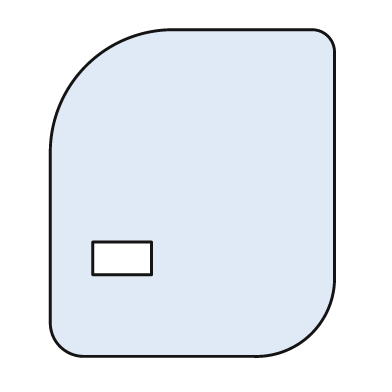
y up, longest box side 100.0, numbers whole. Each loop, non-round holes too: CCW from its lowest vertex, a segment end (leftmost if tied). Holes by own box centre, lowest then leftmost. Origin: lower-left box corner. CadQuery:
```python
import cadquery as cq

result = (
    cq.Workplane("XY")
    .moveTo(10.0, 0.0)
    .lineTo(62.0, 0.0)
    .threePointArc((80.0, 7.0), (87.0, 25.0))
    .lineTo(87.0, 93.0)
    .threePointArc((85.0, 98.0), (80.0, 100.0))
    .lineTo(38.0, 100.0)
    .threePointArc((11.0, 89.0), (0.0, 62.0))
    .lineTo(0.0, 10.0)
    .threePointArc((3.0, 3.0), (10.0, 0.0))
    .close()
    .moveTo(13.0, 25.0)
    .lineTo(31.0, 25.0)
    .lineTo(31.0, 35.0)
    .lineTo(13.0, 35.0)
    .close()
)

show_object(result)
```